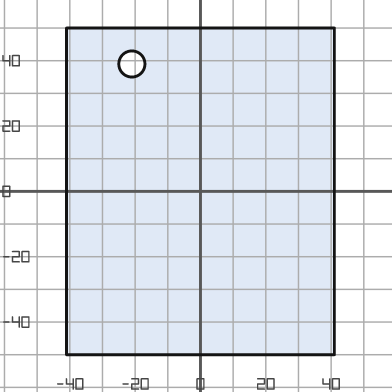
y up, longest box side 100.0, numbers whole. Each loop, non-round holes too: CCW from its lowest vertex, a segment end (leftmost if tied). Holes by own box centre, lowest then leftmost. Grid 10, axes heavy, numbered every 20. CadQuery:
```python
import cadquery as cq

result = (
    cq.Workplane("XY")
    .moveTo(-41.0, -50.0)
    .lineTo(41.0, -50.0)
    .lineTo(41.0, 50.0)
    .lineTo(-41.0, 50.0)
    .close()
    .moveTo(-21.0, 39.0)
    .circle(4.0)
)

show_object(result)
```